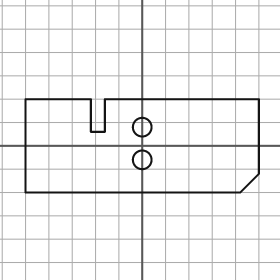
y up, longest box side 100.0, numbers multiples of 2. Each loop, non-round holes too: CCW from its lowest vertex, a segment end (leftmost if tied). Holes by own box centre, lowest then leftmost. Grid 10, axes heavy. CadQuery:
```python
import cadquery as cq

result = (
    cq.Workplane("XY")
    .moveTo(-50.0, -20.0)
    .lineTo(42.0, -20.0)
    .lineTo(50.0, -12.0)
    .lineTo(50.0, 20.0)
    .lineTo(-16.0, 20.0)
    .lineTo(-16.0, 6.0)
    .lineTo(-22.0, 6.0)
    .lineTo(-22.0, 20.0)
    .lineTo(-50.0, 20.0)
    .close()
    .moveTo(0.0, -6.0)
    .circle(4.0)
    .moveTo(0.0, 8.0)
    .circle(4.0)
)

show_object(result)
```